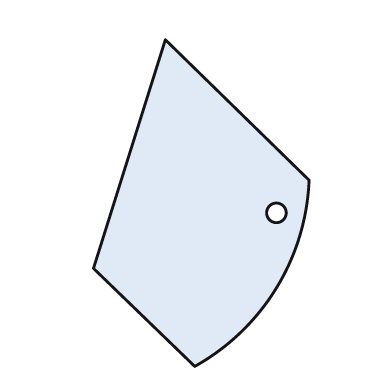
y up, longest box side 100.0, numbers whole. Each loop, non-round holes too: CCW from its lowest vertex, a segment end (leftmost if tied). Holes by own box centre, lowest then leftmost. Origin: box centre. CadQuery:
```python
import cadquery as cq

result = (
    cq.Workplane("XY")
    .moveTo(-2.0, -50.0)
    .threePointArc((23.0, -26.0), (33.0, 7.0))
    .lineTo(-11.0, 50.0)
    .lineTo(-33.0, -20.0)
    .close()
    .moveTo(23.0, -3.0)
    .circle(3.0)
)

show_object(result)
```